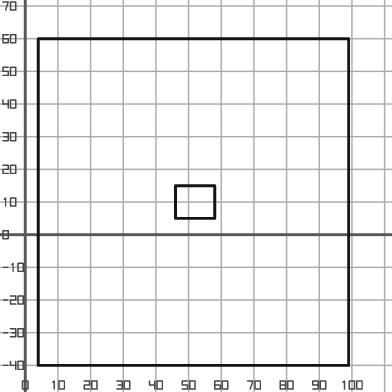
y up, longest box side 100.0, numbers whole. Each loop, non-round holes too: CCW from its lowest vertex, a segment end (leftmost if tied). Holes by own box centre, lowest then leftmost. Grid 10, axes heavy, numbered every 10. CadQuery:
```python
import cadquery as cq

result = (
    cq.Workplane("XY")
    .moveTo(4.0, -40.0)
    .lineTo(99.0, -40.0)
    .lineTo(99.0, 60.0)
    .lineTo(4.0, 60.0)
    .close()
    .moveTo(46.0, 5.0)
    .lineTo(58.0, 5.0)
    .lineTo(58.0, 15.0)
    .lineTo(46.0, 15.0)
    .close()
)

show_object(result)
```